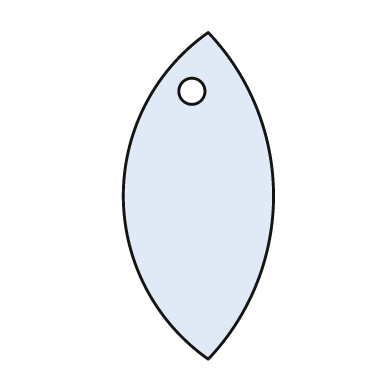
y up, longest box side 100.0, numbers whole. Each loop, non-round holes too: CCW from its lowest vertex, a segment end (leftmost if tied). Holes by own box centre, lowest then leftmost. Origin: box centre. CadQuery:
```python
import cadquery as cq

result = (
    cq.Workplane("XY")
    .moveTo(3.0, -50.0)
    .threePointArc((23.0, 0.0), (3.0, 50.0))
    .threePointArc((-23.0, 0.0), (3.0, -50.0))
    .close()
    .moveTo(-2.0, 32.0)
    .circle(4.0)
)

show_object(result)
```